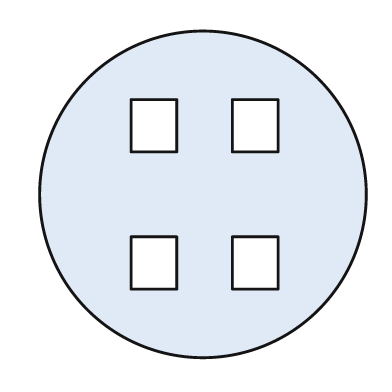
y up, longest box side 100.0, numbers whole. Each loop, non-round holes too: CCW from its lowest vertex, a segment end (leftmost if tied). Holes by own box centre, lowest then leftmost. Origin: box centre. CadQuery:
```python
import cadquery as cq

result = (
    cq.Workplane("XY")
    .moveTo(0.0, 0.0)
    .circle(50.0)
    .moveTo(-22.0, -29.0)
    .lineTo(-8.0, -29.0)
    .lineTo(-8.0, -13.0)
    .lineTo(-22.0, -13.0)
    .close()
    .moveTo(9.0, -29.0)
    .lineTo(23.0, -29.0)
    .lineTo(23.0, -13.0)
    .lineTo(9.0, -13.0)
    .close()
    .moveTo(-22.0, 13.0)
    .lineTo(-8.0, 13.0)
    .lineTo(-8.0, 29.0)
    .lineTo(-22.0, 29.0)
    .close()
    .moveTo(9.0, 13.0)
    .lineTo(23.0, 13.0)
    .lineTo(23.0, 29.0)
    .lineTo(9.0, 29.0)
    .close()
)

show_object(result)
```